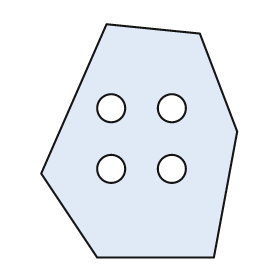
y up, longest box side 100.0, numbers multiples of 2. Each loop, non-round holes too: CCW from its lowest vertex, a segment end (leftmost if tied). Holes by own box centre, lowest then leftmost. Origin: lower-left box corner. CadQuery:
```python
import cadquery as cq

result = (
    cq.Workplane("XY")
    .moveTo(24.0, 0.0)
    .lineTo(74.0, 0.0)
    .lineTo(84.0, 54.0)
    .lineTo(68.0, 96.0)
    .lineTo(28.0, 100.0)
    .lineTo(0.0, 36.0)
    .close()
    .moveTo(30.0, 38.0)
    .circle(6.0)
    .moveTo(56.0, 38.0)
    .circle(6.0)
    .moveTo(30.0, 64.0)
    .circle(6.0)
    .moveTo(56.0, 64.0)
    .circle(6.0)
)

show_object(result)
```